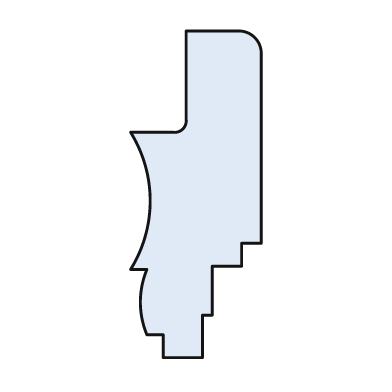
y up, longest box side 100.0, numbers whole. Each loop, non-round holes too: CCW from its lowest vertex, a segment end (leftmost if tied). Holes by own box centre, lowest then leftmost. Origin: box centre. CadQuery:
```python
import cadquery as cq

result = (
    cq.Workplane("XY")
    .moveTo(-10.0, -50.0)
    .lineTo(2.0, -50.0)
    .lineTo(2.0, -37.0)
    .lineTo(5.0, -37.0)
    .lineTo(5.0, -22.0)
    .lineTo(14.0, -22.0)
    .lineTo(14.0, -15.0)
    .lineTo(20.0, -15.0)
    .lineTo(20.0, 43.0)
    .threePointArc((18.0, 48.0), (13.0, 50.0))
    .lineTo(-3.0, 50.0)
    .lineTo(-3.0, 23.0)
    .threePointArc((-4.0, 20.0), (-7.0, 19.0))
    .lineTo(-20.0, 19.0)
    .threePointArc((-14.0, -2.0), (-20.0, -23.0))
    .lineTo(-15.0, -23.0)
    .threePointArc((-17.0, -33.0), (-15.0, -43.0))
    .lineTo(-10.0, -43.0)
    .close()
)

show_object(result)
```